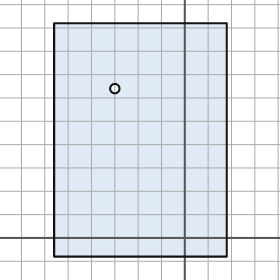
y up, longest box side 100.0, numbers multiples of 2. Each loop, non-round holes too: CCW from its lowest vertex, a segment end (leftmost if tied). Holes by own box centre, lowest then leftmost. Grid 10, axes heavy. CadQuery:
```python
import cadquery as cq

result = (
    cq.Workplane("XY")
    .moveTo(-56.0, -8.0)
    .lineTo(18.0, -8.0)
    .lineTo(18.0, 92.0)
    .lineTo(-56.0, 92.0)
    .close()
    .moveTo(-30.0, 64.0)
    .circle(2.0)
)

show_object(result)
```